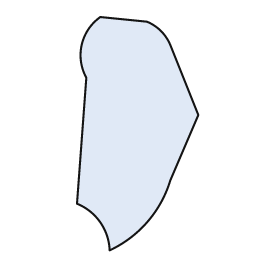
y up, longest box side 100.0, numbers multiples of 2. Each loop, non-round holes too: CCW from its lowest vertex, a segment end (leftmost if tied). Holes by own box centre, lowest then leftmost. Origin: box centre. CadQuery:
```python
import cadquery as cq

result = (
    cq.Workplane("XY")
    .moveTo(-12.0, -50.0)
    .threePointArc((4.0, -38.0), (14.0, -20.0))
    .lineTo(26.0, 8.0)
    .lineTo(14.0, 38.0)
    .threePointArc((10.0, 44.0), (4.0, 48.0))
    .lineTo(-16.0, 50.0)
    .threePointArc((-24.0, 38.0), (-22.0, 24.0))
    .lineTo(-26.0, -30.0)
    .threePointArc((-16.0, -38.0), (-12.0, -50.0))
    .close()
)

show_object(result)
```